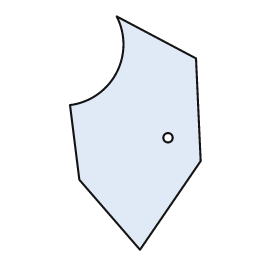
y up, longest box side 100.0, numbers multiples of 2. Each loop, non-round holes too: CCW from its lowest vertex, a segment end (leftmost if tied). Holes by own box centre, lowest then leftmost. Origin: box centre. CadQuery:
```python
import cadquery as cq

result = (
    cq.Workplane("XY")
    .moveTo(2.0, -50.0)
    .lineTo(28.0, -12.0)
    .lineTo(26.0, 32.0)
    .lineTo(-8.0, 50.0)
    .threePointArc((-8.0, 26.0), (-28.0, 12.0))
    .lineTo(-24.0, -20.0)
    .close()
    .moveTo(14.0, -2.0)
    .circle(2.0)
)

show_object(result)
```